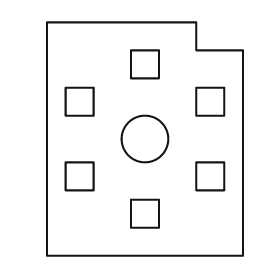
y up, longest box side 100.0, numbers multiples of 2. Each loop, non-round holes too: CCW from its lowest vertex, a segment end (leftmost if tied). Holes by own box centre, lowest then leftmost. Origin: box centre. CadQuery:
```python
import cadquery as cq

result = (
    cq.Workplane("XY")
    .moveTo(-42.0, -50.0)
    .lineTo(42.0, -50.0)
    .lineTo(42.0, 38.0)
    .lineTo(22.0, 38.0)
    .lineTo(22.0, 50.0)
    .lineTo(-42.0, 50.0)
    .close()
    .moveTo(-6.0, -38.0)
    .lineTo(6.0, -38.0)
    .lineTo(6.0, -26.0)
    .lineTo(-6.0, -26.0)
    .close()
    .moveTo(-34.0, -22.0)
    .lineTo(-22.0, -22.0)
    .lineTo(-22.0, -10.0)
    .lineTo(-34.0, -10.0)
    .close()
    .moveTo(22.0, -22.0)
    .lineTo(34.0, -22.0)
    .lineTo(34.0, -10.0)
    .lineTo(22.0, -10.0)
    .close()
    .moveTo(0.0, 0.0)
    .circle(10.0)
    .moveTo(-34.0, 10.0)
    .lineTo(-22.0, 10.0)
    .lineTo(-22.0, 22.0)
    .lineTo(-34.0, 22.0)
    .close()
    .moveTo(22.0, 10.0)
    .lineTo(34.0, 10.0)
    .lineTo(34.0, 22.0)
    .lineTo(22.0, 22.0)
    .close()
    .moveTo(-6.0, 26.0)
    .lineTo(6.0, 26.0)
    .lineTo(6.0, 38.0)
    .lineTo(-6.0, 38.0)
    .close()
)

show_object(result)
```